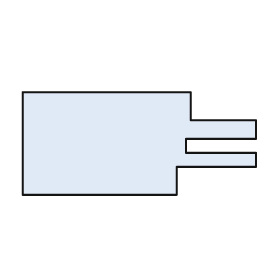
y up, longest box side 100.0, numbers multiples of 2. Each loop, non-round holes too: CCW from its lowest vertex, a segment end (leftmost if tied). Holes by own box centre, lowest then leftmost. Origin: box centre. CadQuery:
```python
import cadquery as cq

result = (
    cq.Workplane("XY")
    .moveTo(-50.0, -22.0)
    .lineTo(16.0, -22.0)
    .lineTo(16.0, -10.0)
    .lineTo(50.0, -10.0)
    .lineTo(50.0, -4.0)
    .lineTo(20.0, -4.0)
    .lineTo(20.0, 2.0)
    .lineTo(50.0, 2.0)
    .lineTo(50.0, 10.0)
    .lineTo(22.0, 10.0)
    .lineTo(22.0, 22.0)
    .lineTo(-50.0, 22.0)
    .close()
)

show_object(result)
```